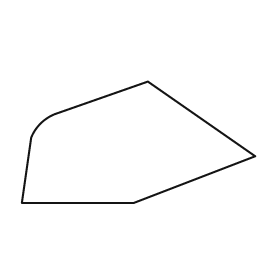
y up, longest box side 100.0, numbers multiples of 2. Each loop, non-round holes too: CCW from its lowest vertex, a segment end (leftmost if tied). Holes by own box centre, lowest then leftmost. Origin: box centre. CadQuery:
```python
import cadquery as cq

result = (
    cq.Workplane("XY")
    .moveTo(-50.0, -26.0)
    .lineTo(-2.0, -26.0)
    .lineTo(50.0, -6.0)
    .lineTo(4.0, 26.0)
    .lineTo(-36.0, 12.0)
    .threePointArc((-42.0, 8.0), (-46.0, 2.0))
    .close()
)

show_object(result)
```